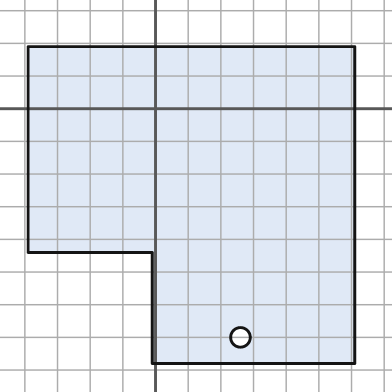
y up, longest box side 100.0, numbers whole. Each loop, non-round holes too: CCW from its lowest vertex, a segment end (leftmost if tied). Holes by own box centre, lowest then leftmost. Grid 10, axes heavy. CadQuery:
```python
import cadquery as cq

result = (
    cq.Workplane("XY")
    .moveTo(-1.0, -78.0)
    .lineTo(61.0, -78.0)
    .lineTo(61.0, 19.0)
    .lineTo(-39.0, 19.0)
    .lineTo(-39.0, -44.0)
    .lineTo(-1.0, -44.0)
    .close()
    .moveTo(26.0, -70.0)
    .circle(3.0)
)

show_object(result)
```